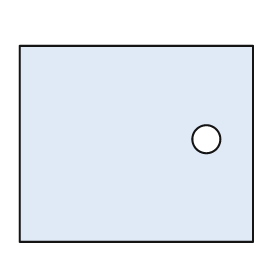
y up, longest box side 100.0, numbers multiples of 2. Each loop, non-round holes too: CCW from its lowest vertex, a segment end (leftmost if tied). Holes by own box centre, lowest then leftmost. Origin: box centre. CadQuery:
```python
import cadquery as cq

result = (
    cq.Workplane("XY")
    .moveTo(-50.0, -42.0)
    .lineTo(50.0, -42.0)
    .lineTo(50.0, 42.0)
    .lineTo(-50.0, 42.0)
    .close()
    .moveTo(30.0, 2.0)
    .circle(6.0)
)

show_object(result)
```